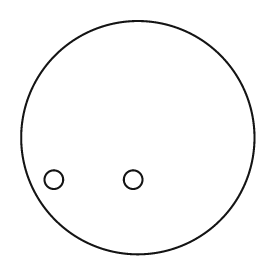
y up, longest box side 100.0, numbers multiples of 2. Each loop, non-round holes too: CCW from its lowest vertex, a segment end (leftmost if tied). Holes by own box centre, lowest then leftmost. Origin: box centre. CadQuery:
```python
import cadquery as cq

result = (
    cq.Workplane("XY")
    .moveTo(0.0, 0.0)
    .circle(50.0)
    .moveTo(-36.0, -18.0)
    .circle(4.0)
    .moveTo(-2.0, -18.0)
    .circle(4.0)
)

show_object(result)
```